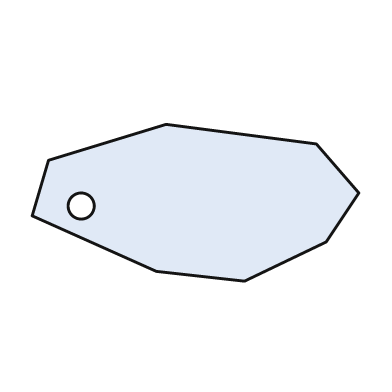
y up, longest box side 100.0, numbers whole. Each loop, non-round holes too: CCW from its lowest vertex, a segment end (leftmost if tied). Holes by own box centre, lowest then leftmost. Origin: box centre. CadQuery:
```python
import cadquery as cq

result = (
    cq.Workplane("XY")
    .moveTo(15.0, -24.0)
    .lineTo(40.0, -12.0)
    .lineTo(50.0, 3.0)
    .lineTo(37.0, 18.0)
    .lineTo(-9.0, 24.0)
    .lineTo(-45.0, 13.0)
    .lineTo(-50.0, -4.0)
    .lineTo(-12.0, -21.0)
    .close()
    .moveTo(-35.0, -1.0)
    .circle(4.0)
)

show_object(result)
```